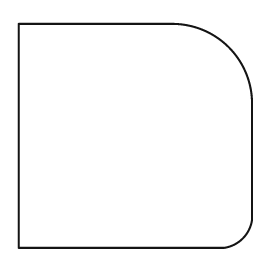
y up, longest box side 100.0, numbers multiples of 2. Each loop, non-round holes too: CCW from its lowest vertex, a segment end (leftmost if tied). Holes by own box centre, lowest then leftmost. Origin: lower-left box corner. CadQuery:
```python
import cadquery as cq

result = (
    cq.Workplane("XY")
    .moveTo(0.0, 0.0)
    .lineTo(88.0, 0.0)
    .threePointArc((96.0, 4.0), (100.0, 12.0))
    .lineTo(100.0, 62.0)
    .threePointArc((90.0, 86.0), (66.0, 96.0))
    .lineTo(0.0, 96.0)
    .close()
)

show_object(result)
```